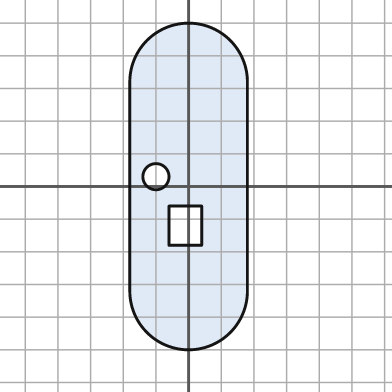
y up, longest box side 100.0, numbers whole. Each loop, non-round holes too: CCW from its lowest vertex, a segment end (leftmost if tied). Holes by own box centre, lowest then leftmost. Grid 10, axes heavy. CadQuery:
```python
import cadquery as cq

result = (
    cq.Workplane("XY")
    .moveTo(-18.0, -32.0)
    .threePointArc((0.0, -50.0), (18.0, -32.0))
    .lineTo(18.0, 32.0)
    .threePointArc((0.0, 50.0), (-18.0, 32.0))
    .close()
    .moveTo(-6.0, -18.0)
    .lineTo(4.0, -18.0)
    .lineTo(4.0, -6.0)
    .lineTo(-6.0, -6.0)
    .close()
    .moveTo(-10.0, 3.0)
    .circle(4.0)
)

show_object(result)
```